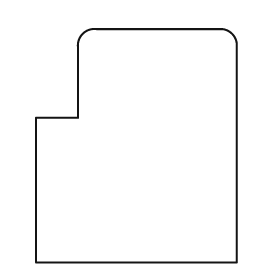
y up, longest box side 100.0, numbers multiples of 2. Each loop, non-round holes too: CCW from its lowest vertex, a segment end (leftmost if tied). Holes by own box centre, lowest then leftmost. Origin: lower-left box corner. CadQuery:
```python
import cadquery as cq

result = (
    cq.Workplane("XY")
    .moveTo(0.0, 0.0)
    .lineTo(86.0, 0.0)
    .lineTo(86.0, 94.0)
    .threePointArc((84.0, 98.0), (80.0, 100.0))
    .lineTo(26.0, 100.0)
    .threePointArc((20.0, 98.0), (18.0, 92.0))
    .lineTo(18.0, 62.0)
    .lineTo(0.0, 62.0)
    .close()
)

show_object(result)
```